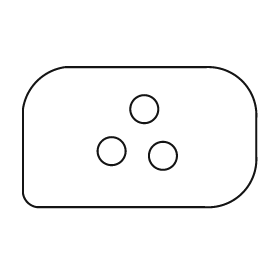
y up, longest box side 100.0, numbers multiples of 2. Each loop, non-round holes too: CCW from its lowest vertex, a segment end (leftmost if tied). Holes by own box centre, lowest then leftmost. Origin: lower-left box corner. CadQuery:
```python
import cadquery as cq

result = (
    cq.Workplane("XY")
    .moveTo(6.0, 0.0)
    .lineTo(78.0, 0.0)
    .threePointArc((94.0, 6.0), (100.0, 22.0))
    .lineTo(100.0, 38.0)
    .threePointArc((94.0, 54.0), (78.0, 60.0))
    .lineTo(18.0, 60.0)
    .threePointArc((6.0, 54.0), (0.0, 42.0))
    .lineTo(0.0, 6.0)
    .threePointArc((2.0, 2.0), (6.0, 0.0))
    .close()
    .moveTo(60.0, 22.0)
    .circle(6.0)
    .moveTo(38.0, 24.0)
    .circle(6.0)
    .moveTo(52.0, 42.0)
    .circle(6.0)
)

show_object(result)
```